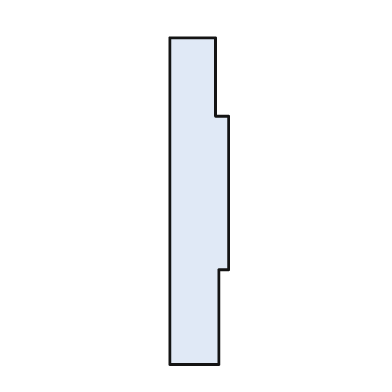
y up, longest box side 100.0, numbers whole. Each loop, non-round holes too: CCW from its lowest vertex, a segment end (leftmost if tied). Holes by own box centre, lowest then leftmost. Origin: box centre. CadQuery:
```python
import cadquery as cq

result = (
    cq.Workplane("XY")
    .moveTo(-9.0, -50.0)
    .lineTo(6.0, -50.0)
    .lineTo(6.0, -21.0)
    .lineTo(9.0, -21.0)
    .lineTo(9.0, 26.0)
    .lineTo(5.0, 26.0)
    .lineTo(5.0, 50.0)
    .lineTo(-9.0, 50.0)
    .close()
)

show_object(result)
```